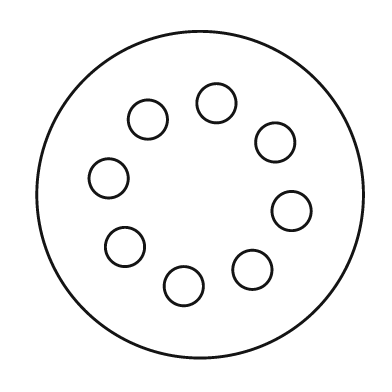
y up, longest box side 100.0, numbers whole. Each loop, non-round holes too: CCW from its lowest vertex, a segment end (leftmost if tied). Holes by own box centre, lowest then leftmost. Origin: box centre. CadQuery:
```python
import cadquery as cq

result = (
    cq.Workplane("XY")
    .moveTo(0.0, 0.0)
    .circle(50.0)
    .moveTo(-5.0, -28.0)
    .circle(6.0)
    .moveTo(16.0, -23.0)
    .circle(6.0)
    .moveTo(-23.0, -16.0)
    .circle(6.0)
    .moveTo(28.0, -5.0)
    .circle(6.0)
    .moveTo(-28.0, 5.0)
    .circle(6.0)
    .moveTo(23.0, 16.0)
    .circle(6.0)
    .moveTo(-16.0, 23.0)
    .circle(6.0)
    .moveTo(5.0, 28.0)
    .circle(6.0)
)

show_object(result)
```